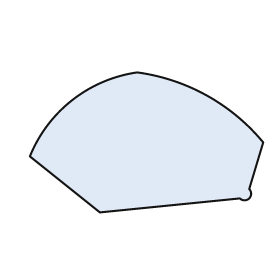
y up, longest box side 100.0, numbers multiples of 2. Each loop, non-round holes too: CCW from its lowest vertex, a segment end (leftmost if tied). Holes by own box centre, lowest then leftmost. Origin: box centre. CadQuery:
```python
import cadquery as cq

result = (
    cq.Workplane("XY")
    .moveTo(-20.0, -30.0)
    .lineTo(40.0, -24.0)
    .threePointArc((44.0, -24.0), (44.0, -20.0))
    .lineTo(50.0, 0.0)
    .threePointArc((26.0, 20.0), (-4.0, 30.0))
    .threePointArc((-32.0, 18.0), (-50.0, -6.0))
    .close()
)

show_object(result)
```